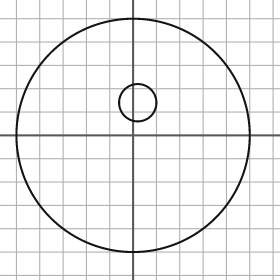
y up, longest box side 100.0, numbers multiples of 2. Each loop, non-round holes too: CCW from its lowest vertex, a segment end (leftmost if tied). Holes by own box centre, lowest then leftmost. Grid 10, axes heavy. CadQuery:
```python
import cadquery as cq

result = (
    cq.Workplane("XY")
    .moveTo(0.0, 0.0)
    .circle(50.0)
    .moveTo(2.0, 14.0)
    .circle(8.0)
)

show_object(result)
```